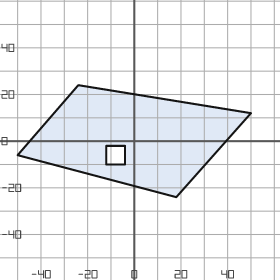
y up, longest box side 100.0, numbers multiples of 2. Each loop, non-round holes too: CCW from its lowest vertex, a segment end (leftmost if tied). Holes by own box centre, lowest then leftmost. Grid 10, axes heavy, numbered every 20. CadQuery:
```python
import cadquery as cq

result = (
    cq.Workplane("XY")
    .moveTo(18.0, -24.0)
    .lineTo(50.0, 12.0)
    .lineTo(-24.0, 24.0)
    .lineTo(-50.0, -6.0)
    .close()
    .moveTo(-12.0, -10.0)
    .lineTo(-4.0, -10.0)
    .lineTo(-4.0, -2.0)
    .lineTo(-12.0, -2.0)
    .close()
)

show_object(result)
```